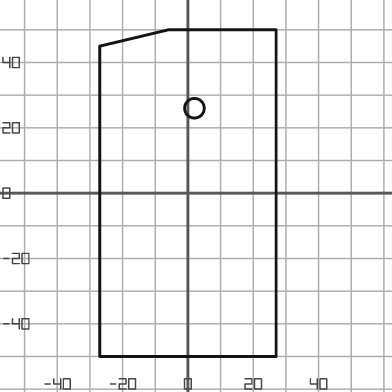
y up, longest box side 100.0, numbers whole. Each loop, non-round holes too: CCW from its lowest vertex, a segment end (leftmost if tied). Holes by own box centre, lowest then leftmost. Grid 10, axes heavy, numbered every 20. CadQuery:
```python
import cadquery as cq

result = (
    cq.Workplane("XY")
    .moveTo(-27.0, -50.0)
    .lineTo(27.0, -50.0)
    .lineTo(27.0, 50.0)
    .lineTo(-6.0, 50.0)
    .lineTo(-27.0, 45.0)
    .close()
    .moveTo(2.0, 26.0)
    .circle(3.0)
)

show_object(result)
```